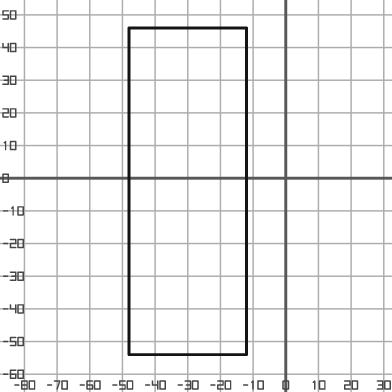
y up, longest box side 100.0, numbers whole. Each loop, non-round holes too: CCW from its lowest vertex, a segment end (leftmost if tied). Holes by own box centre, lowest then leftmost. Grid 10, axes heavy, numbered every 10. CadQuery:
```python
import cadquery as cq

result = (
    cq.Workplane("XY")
    .moveTo(-48.0, -54.0)
    .lineTo(-12.0, -54.0)
    .lineTo(-12.0, 46.0)
    .lineTo(-48.0, 46.0)
    .close()
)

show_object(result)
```